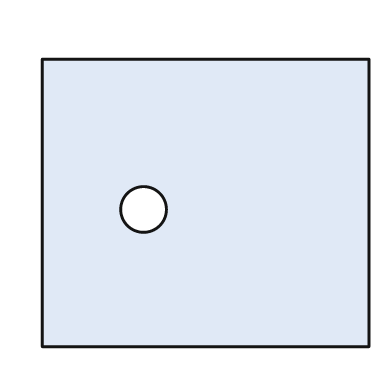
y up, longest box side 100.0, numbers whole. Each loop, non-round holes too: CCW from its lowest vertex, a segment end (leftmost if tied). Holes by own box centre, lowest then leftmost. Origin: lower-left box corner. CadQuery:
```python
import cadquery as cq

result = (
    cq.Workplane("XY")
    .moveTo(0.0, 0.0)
    .lineTo(100.0, 0.0)
    .lineTo(100.0, 88.0)
    .lineTo(0.0, 88.0)
    .close()
    .moveTo(31.0, 42.0)
    .circle(7.0)
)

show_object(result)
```